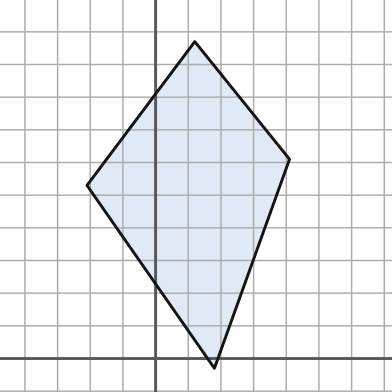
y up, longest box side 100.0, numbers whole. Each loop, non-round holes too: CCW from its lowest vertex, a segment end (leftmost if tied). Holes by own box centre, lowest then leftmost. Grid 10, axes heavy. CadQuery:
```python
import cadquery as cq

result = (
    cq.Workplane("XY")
    .moveTo(18.0, -3.0)
    .lineTo(41.0, 61.0)
    .lineTo(12.0, 97.0)
    .lineTo(-21.0, 53.0)
    .close()
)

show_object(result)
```